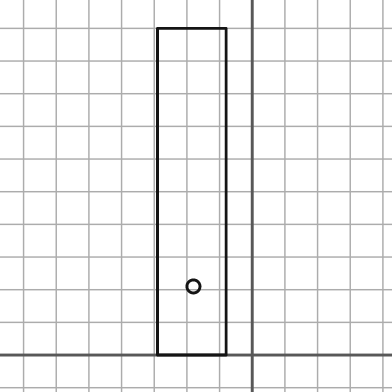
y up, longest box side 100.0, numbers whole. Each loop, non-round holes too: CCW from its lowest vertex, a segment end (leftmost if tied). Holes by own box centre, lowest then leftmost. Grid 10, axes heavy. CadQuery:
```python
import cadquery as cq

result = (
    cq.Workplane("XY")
    .moveTo(-29.0, 0.0)
    .lineTo(-8.0, 0.0)
    .lineTo(-8.0, 100.0)
    .lineTo(-29.0, 100.0)
    .close()
    .moveTo(-18.0, 21.0)
    .circle(2.0)
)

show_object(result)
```